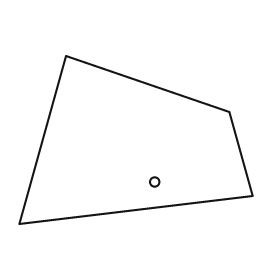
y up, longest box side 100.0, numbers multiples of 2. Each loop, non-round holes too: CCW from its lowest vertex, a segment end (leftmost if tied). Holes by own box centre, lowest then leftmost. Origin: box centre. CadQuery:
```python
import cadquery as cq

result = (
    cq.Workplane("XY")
    .moveTo(-50.0, -36.0)
    .lineTo(50.0, -24.0)
    .lineTo(40.0, 12.0)
    .lineTo(-30.0, 36.0)
    .close()
    .moveTo(8.0, -18.0)
    .circle(2.0)
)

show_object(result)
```